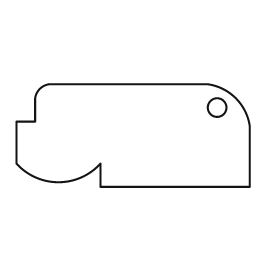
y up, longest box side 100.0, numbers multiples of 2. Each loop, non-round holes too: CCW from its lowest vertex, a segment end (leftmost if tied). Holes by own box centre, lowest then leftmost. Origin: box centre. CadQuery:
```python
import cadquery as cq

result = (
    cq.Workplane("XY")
    .moveTo(-14.0, -22.0)
    .lineTo(50.0, -22.0)
    .lineTo(50.0, 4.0)
    .threePointArc((44.0, 16.0), (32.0, 22.0))
    .lineTo(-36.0, 22.0)
    .threePointArc((-40.0, 20.0), (-42.0, 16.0))
    .lineTo(-42.0, 6.0)
    .lineTo(-50.0, 6.0)
    .lineTo(-50.0, -12.0)
    .threePointArc((-32.0, -20.0), (-14.0, -12.0))
    .close()
    .moveTo(36.0, 12.0)
    .circle(4.0)
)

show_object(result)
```